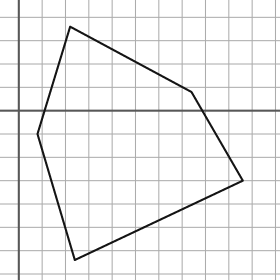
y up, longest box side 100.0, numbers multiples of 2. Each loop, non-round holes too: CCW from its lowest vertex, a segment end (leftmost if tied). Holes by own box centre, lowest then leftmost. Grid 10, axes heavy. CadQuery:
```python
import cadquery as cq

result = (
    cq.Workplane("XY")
    .moveTo(24.0, -64.0)
    .lineTo(96.0, -30.0)
    .lineTo(74.0, 8.0)
    .lineTo(22.0, 36.0)
    .lineTo(8.0, -10.0)
    .close()
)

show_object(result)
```